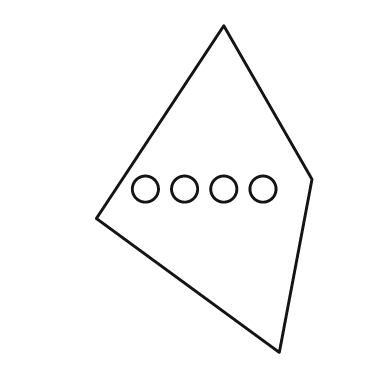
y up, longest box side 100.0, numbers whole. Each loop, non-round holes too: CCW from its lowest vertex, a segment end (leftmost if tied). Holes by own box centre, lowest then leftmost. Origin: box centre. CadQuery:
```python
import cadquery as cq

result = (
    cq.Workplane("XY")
    .moveTo(23.0, -50.0)
    .lineTo(33.0, 3.0)
    .lineTo(6.0, 50.0)
    .lineTo(-33.0, -9.0)
    .close()
    .moveTo(-18.0, 0.0)
    .circle(4.0)
    .moveTo(-6.0, 0.0)
    .circle(4.0)
    .moveTo(6.0, 0.0)
    .circle(4.0)
    .moveTo(18.0, 0.0)
    .circle(4.0)
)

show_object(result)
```